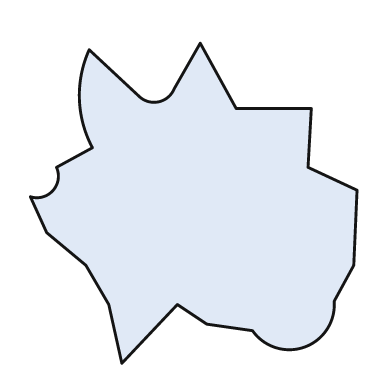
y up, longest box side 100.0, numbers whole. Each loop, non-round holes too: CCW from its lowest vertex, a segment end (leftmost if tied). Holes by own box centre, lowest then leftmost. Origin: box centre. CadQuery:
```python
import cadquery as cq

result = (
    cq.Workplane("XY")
    .moveTo(-22.0, -49.0)
    .lineTo(-5.0, -31.0)
    .lineTo(4.0, -37.0)
    .lineTo(18.0, -39.0)
    .threePointArc((34.0, -44.0), (43.0, -30.0))
    .lineTo(49.0, -19.0)
    .lineTo(50.0, 4.0)
    .lineTo(35.0, 11.0)
    .lineTo(36.0, 29.0)
    .lineTo(13.0, 29.0)
    .lineTo(2.0, 49.0)
    .lineTo(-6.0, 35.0)
    .threePointArc((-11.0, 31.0), (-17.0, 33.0))
    .lineTo(-32.0, 47.0)
    .threePointArc((-35.0, 32.0), (-31.0, 17.0))
    .lineTo(-42.0, 11.0)
    .threePointArc((-43.0, 4.0), (-50.0, 2.0))
    .lineTo(-45.0, -9.0)
    .lineTo(-33.0, -19.0)
    .lineTo(-26.0, -31.0)
    .close()
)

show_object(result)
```